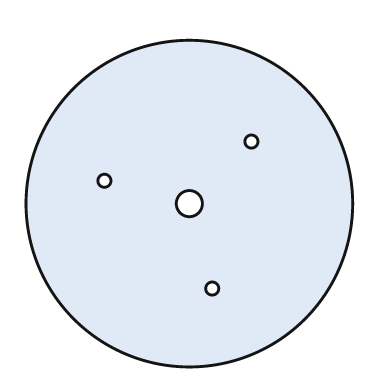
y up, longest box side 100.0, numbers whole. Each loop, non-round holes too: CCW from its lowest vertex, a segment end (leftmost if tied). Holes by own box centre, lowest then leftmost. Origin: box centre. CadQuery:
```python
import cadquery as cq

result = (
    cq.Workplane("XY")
    .moveTo(0.0, 0.0)
    .circle(50.0)
    .moveTo(7.0, -26.0)
    .circle(2.0)
    .moveTo(0.0, 0.0)
    .circle(4.0)
    .moveTo(-26.0, 7.0)
    .circle(2.0)
    .moveTo(19.0, 19.0)
    .circle(2.0)
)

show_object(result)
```